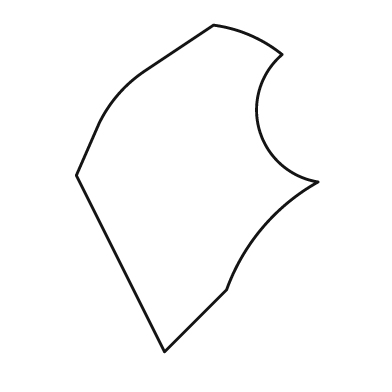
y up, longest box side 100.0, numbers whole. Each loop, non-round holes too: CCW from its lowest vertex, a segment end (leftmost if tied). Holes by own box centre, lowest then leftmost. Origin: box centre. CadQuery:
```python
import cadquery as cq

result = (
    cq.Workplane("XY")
    .moveTo(-10.0, -50.0)
    .lineTo(9.0, -31.0)
    .threePointArc((20.0, -12.0), (37.0, 2.0))
    .threePointArc((19.0, 18.0), (26.0, 41.0))
    .threePointArc((16.0, 47.0), (5.0, 50.0))
    .lineTo(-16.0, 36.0)
    .threePointArc((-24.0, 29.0), (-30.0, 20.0))
    .lineTo(-37.0, 4.0)
    .close()
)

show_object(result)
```